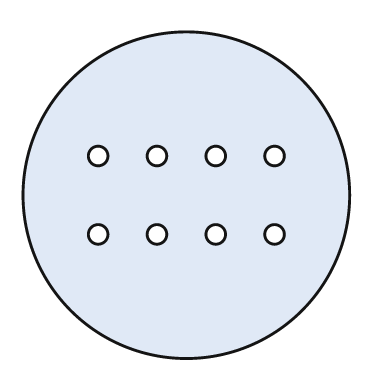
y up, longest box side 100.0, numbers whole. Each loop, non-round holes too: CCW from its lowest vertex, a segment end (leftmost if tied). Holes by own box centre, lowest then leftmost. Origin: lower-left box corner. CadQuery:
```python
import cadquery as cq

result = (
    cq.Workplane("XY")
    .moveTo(50.0, 50.0)
    .circle(50.0)
    .moveTo(23.0, 38.0)
    .circle(3.0)
    .moveTo(41.0, 38.0)
    .circle(3.0)
    .moveTo(59.0, 38.0)
    .circle(3.0)
    .moveTo(77.0, 38.0)
    .circle(3.0)
    .moveTo(23.0, 62.0)
    .circle(3.0)
    .moveTo(41.0, 62.0)
    .circle(3.0)
    .moveTo(59.0, 62.0)
    .circle(3.0)
    .moveTo(77.0, 62.0)
    .circle(3.0)
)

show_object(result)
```